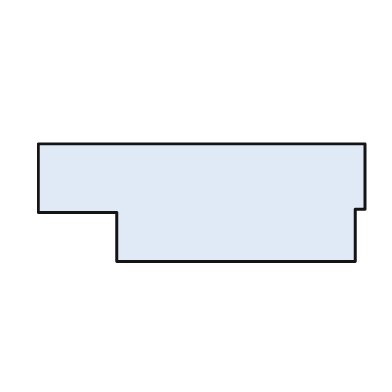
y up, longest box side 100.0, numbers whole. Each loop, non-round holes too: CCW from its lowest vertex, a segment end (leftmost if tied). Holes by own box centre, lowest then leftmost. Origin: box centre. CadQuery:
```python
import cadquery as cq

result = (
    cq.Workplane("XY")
    .moveTo(-26.0, -18.0)
    .lineTo(47.0, -18.0)
    .lineTo(47.0, -2.0)
    .lineTo(50.0, -2.0)
    .lineTo(50.0, 18.0)
    .lineTo(-50.0, 18.0)
    .lineTo(-50.0, -3.0)
    .lineTo(-26.0, -3.0)
    .close()
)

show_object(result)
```